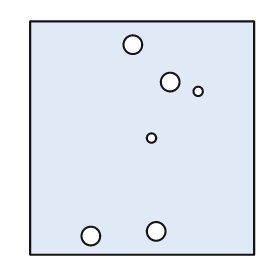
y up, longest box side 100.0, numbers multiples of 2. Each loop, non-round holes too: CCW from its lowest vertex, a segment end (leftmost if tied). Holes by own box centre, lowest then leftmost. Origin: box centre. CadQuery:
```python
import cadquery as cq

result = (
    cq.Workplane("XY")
    .moveTo(-48.0, -50.0)
    .lineTo(48.0, -50.0)
    .lineTo(48.0, 50.0)
    .lineTo(-48.0, 50.0)
    .close()
    .moveTo(-22.0, -42.0)
    .circle(4.0)
    .moveTo(6.0, -40.0)
    .circle(4.0)
    .moveTo(4.0, 0.0)
    .circle(2.0)
    .moveTo(24.0, 20.0)
    .circle(2.0)
    .moveTo(12.0, 24.0)
    .circle(4.0)
    .moveTo(-4.0, 40.0)
    .circle(4.0)
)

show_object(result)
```